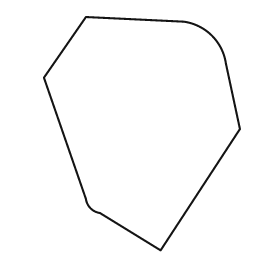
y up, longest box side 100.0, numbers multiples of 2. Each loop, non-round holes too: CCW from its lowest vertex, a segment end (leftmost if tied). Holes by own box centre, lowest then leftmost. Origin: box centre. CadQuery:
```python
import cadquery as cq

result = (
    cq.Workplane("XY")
    .moveTo(8.0, -50.0)
    .lineTo(42.0, 2.0)
    .lineTo(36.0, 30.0)
    .threePointArc((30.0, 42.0), (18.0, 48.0))
    .lineTo(-24.0, 50.0)
    .lineTo(-42.0, 24.0)
    .lineTo(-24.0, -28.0)
    .threePointArc((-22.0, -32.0), (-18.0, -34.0))
    .close()
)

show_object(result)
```